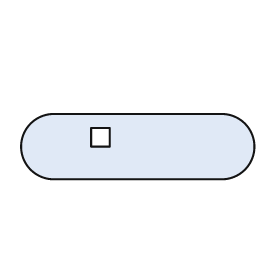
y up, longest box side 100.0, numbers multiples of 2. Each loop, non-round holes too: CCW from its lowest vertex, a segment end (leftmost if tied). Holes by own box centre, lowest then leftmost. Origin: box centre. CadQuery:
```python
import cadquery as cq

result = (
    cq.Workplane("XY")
    .moveTo(-36.0, -14.0)
    .lineTo(36.0, -14.0)
    .threePointArc((50.0, 0.0), (36.0, 14.0))
    .lineTo(-36.0, 14.0)
    .threePointArc((-50.0, 0.0), (-36.0, -14.0))
    .close()
    .moveTo(-20.0, 0.0)
    .lineTo(-12.0, 0.0)
    .lineTo(-12.0, 8.0)
    .lineTo(-20.0, 8.0)
    .close()
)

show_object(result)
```